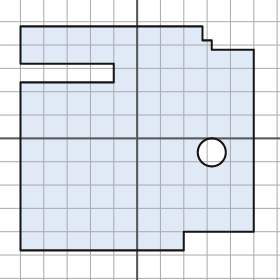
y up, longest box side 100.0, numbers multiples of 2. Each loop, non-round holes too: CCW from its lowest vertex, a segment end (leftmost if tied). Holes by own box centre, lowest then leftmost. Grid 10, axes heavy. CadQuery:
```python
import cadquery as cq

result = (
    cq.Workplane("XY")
    .moveTo(-50.0, -48.0)
    .lineTo(20.0, -48.0)
    .lineTo(20.0, -40.0)
    .lineTo(50.0, -40.0)
    .lineTo(50.0, 38.0)
    .lineTo(32.0, 38.0)
    .lineTo(32.0, 42.0)
    .lineTo(28.0, 42.0)
    .lineTo(28.0, 48.0)
    .lineTo(-50.0, 48.0)
    .lineTo(-50.0, 32.0)
    .lineTo(-10.0, 32.0)
    .lineTo(-10.0, 24.0)
    .lineTo(-50.0, 24.0)
    .close()
    .moveTo(32.0, -6.0)
    .circle(6.0)
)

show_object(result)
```